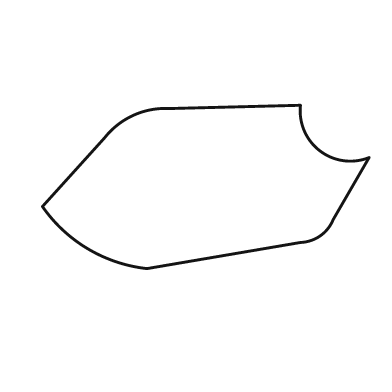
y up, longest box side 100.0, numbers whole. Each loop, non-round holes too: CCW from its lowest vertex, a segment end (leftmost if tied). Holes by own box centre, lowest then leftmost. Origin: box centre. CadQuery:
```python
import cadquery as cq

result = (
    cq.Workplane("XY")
    .moveTo(-18.0, -25.0)
    .lineTo(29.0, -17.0)
    .threePointArc((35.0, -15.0), (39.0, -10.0))
    .lineTo(50.0, 9.0)
    .threePointArc((35.0, 11.0), (29.0, 25.0))
    .lineTo(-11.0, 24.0)
    .threePointArc((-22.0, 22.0), (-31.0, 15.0))
    .lineTo(-50.0, -6.0)
    .threePointArc((-36.0, -19.0), (-18.0, -25.0))
    .close()
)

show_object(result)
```